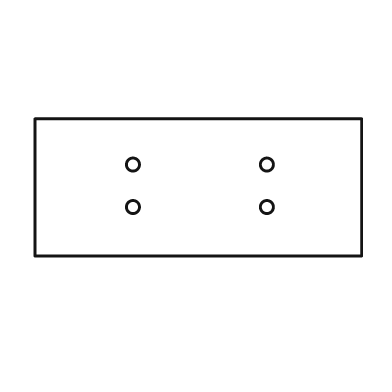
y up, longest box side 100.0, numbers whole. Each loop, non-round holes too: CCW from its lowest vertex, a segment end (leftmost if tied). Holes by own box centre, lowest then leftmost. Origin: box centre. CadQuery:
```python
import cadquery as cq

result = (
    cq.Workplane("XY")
    .moveTo(-50.0, -21.0)
    .lineTo(50.0, -21.0)
    .lineTo(50.0, 21.0)
    .lineTo(-50.0, 21.0)
    .close()
    .moveTo(-20.0, -6.0)
    .circle(2.0)
    .moveTo(21.0, -6.0)
    .circle(2.0)
    .moveTo(-20.0, 7.0)
    .circle(2.0)
    .moveTo(21.0, 7.0)
    .circle(2.0)
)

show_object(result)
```